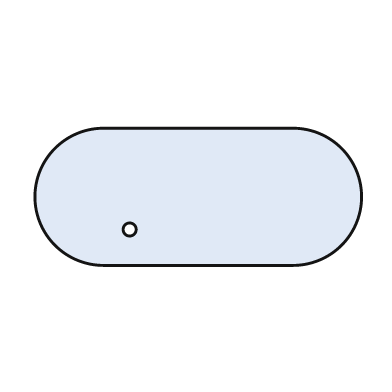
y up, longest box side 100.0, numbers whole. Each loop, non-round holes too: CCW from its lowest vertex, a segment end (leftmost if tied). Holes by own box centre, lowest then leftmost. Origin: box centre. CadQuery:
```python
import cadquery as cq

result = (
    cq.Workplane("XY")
    .moveTo(-29.0, -21.0)
    .lineTo(29.0, -21.0)
    .threePointArc((50.0, 0.0), (29.0, 21.0))
    .lineTo(-29.0, 21.0)
    .threePointArc((-50.0, 0.0), (-29.0, -21.0))
    .close()
    .moveTo(-21.0, -10.0)
    .circle(2.0)
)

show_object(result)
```